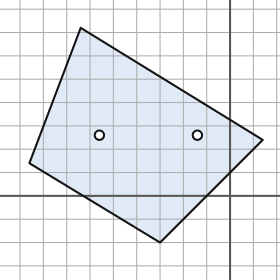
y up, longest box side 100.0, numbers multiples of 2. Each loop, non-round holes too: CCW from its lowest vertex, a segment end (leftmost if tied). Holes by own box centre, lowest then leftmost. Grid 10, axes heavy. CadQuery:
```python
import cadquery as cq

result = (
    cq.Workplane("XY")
    .moveTo(-30.0, -20.0)
    .lineTo(14.0, 24.0)
    .lineTo(-64.0, 72.0)
    .lineTo(-86.0, 14.0)
    .close()
    .moveTo(-56.0, 26.0)
    .circle(2.0)
    .moveTo(-14.0, 26.0)
    .circle(2.0)
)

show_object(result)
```